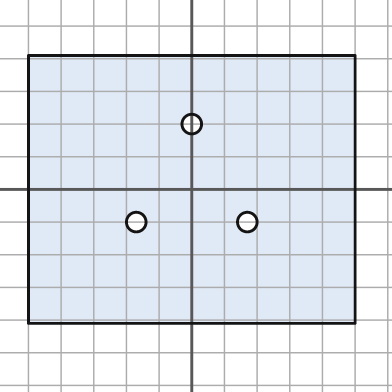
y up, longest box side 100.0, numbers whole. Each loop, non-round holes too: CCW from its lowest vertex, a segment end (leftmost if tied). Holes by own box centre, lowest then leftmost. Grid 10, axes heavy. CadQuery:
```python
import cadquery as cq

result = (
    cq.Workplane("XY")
    .moveTo(-50.0, -41.0)
    .lineTo(50.0, -41.0)
    .lineTo(50.0, 41.0)
    .lineTo(-50.0, 41.0)
    .close()
    .moveTo(-17.0, -10.0)
    .circle(3.0)
    .moveTo(17.0, -10.0)
    .circle(3.0)
    .moveTo(0.0, 20.0)
    .circle(3.0)
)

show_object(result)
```